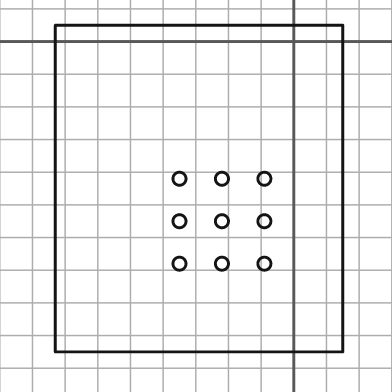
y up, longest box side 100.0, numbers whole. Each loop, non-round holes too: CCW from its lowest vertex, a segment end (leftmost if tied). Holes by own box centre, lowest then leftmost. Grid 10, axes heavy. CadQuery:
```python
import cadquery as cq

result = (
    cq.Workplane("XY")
    .moveTo(-73.0, -95.0)
    .lineTo(15.0, -95.0)
    .lineTo(15.0, 5.0)
    .lineTo(-73.0, 5.0)
    .close()
    .moveTo(-35.0, -68.0)
    .circle(2.0)
    .moveTo(-22.0, -68.0)
    .circle(2.0)
    .moveTo(-9.0, -68.0)
    .circle(2.0)
    .moveTo(-35.0, -55.0)
    .circle(2.0)
    .moveTo(-22.0, -55.0)
    .circle(2.0)
    .moveTo(-9.0, -55.0)
    .circle(2.0)
    .moveTo(-35.0, -42.0)
    .circle(2.0)
    .moveTo(-22.0, -42.0)
    .circle(2.0)
    .moveTo(-9.0, -42.0)
    .circle(2.0)
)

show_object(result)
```